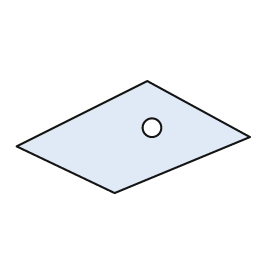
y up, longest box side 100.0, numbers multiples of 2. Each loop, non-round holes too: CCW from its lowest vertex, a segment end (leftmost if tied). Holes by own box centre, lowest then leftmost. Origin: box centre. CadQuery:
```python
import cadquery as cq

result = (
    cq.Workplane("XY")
    .moveTo(-8.0, -24.0)
    .lineTo(50.0, 0.0)
    .lineTo(6.0, 24.0)
    .lineTo(-50.0, -4.0)
    .close()
    .moveTo(8.0, 4.0)
    .circle(4.0)
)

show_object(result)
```